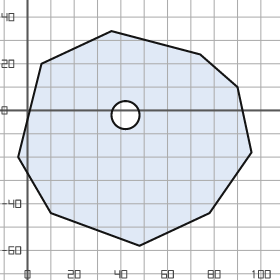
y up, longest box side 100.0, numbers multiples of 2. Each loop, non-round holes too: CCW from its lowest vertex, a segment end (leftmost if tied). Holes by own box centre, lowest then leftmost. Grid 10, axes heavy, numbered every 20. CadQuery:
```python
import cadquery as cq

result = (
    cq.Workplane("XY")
    .moveTo(48.0, -58.0)
    .lineTo(78.0, -44.0)
    .lineTo(96.0, -18.0)
    .lineTo(90.0, 10.0)
    .lineTo(74.0, 24.0)
    .lineTo(36.0, 34.0)
    .lineTo(6.0, 20.0)
    .lineTo(-4.0, -20.0)
    .lineTo(10.0, -44.0)
    .close()
    .moveTo(42.0, -2.0)
    .circle(6.0)
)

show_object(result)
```